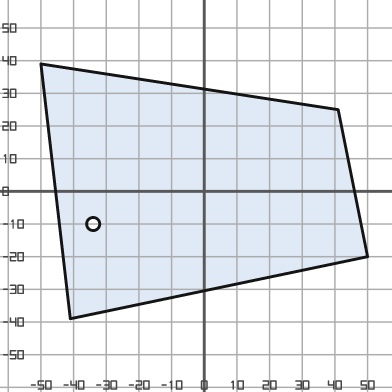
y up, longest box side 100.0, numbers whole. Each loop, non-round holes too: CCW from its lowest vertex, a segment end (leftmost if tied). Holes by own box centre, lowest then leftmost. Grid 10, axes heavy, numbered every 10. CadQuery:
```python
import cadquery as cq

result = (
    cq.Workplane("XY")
    .moveTo(-41.0, -39.0)
    .lineTo(50.0, -20.0)
    .lineTo(41.0, 25.0)
    .lineTo(-50.0, 39.0)
    .close()
    .moveTo(-34.0, -10.0)
    .circle(2.0)
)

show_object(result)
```